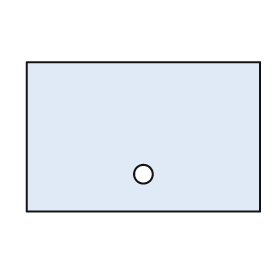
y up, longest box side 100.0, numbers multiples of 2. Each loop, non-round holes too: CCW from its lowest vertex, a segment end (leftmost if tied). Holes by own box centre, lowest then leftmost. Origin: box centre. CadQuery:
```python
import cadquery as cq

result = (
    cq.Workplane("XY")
    .moveTo(-50.0, -32.0)
    .lineTo(50.0, -32.0)
    .lineTo(50.0, 32.0)
    .lineTo(-50.0, 32.0)
    .close()
    .moveTo(0.0, -16.0)
    .circle(4.0)
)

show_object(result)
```